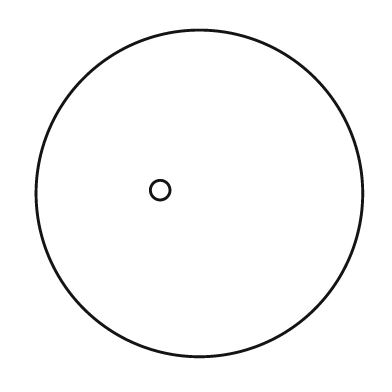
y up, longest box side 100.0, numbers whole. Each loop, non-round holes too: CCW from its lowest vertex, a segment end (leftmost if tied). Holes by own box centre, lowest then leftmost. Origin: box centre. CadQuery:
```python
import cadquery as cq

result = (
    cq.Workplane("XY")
    .moveTo(0.0, 0.0)
    .circle(50.0)
    .moveTo(-12.0, 1.0)
    .circle(3.0)
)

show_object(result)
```